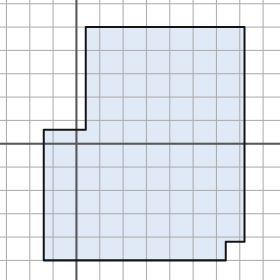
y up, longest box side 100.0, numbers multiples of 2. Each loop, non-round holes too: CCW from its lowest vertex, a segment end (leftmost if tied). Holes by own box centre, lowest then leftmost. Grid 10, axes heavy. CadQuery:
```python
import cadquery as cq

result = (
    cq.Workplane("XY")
    .moveTo(-14.0, -50.0)
    .lineTo(64.0, -50.0)
    .lineTo(64.0, -42.0)
    .lineTo(72.0, -42.0)
    .lineTo(72.0, 50.0)
    .lineTo(4.0, 50.0)
    .lineTo(4.0, 6.0)
    .lineTo(-14.0, 6.0)
    .close()
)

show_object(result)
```